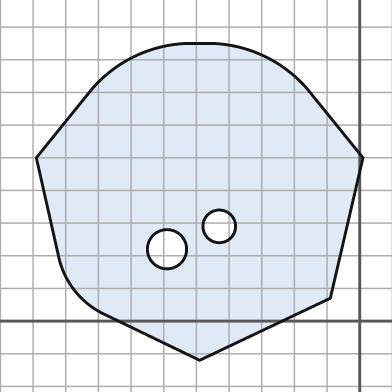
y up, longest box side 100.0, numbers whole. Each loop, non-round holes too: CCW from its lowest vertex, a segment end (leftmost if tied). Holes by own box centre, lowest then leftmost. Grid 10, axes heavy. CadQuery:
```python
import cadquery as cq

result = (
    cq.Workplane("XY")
    .moveTo(-49.0, -12.0)
    .lineTo(-9.0, 7.0)
    .lineTo(1.0, 50.0)
    .lineTo(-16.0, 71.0)
    .threePointArc((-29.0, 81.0), (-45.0, 85.0))
    .lineTo(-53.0, 85.0)
    .threePointArc((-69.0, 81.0), (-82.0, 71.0))
    .lineTo(-99.0, 50.0)
    .lineTo(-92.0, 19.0)
    .threePointArc((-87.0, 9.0), (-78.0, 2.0))
    .close()
    .moveTo(-59.0, 22.0)
    .circle(6.0)
    .moveTo(-43.0, 29.0)
    .circle(5.0)
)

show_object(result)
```